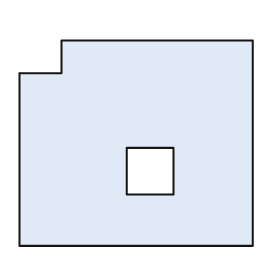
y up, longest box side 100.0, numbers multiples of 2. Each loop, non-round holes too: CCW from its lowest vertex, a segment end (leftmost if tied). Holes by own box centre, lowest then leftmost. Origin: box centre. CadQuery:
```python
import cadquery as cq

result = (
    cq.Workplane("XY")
    .moveTo(-50.0, -44.0)
    .lineTo(50.0, -44.0)
    .lineTo(50.0, 44.0)
    .lineTo(-32.0, 44.0)
    .lineTo(-32.0, 30.0)
    .lineTo(-50.0, 30.0)
    .close()
    .moveTo(-4.0, -22.0)
    .lineTo(16.0, -22.0)
    .lineTo(16.0, -2.0)
    .lineTo(-4.0, -2.0)
    .close()
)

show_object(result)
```